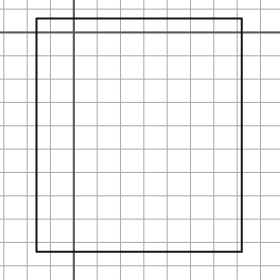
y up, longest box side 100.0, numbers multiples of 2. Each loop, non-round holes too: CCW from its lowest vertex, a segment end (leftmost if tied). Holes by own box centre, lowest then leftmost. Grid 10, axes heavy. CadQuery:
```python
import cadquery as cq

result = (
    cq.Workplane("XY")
    .moveTo(-16.0, -94.0)
    .lineTo(72.0, -94.0)
    .lineTo(72.0, 6.0)
    .lineTo(-16.0, 6.0)
    .close()
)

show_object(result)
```